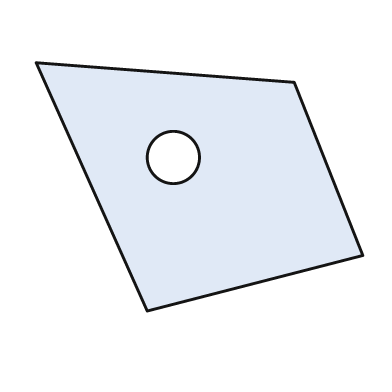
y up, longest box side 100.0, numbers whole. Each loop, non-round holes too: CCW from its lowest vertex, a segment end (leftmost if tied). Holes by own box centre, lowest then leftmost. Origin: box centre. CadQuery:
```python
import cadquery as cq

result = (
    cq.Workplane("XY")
    .moveTo(-16.0, -38.0)
    .lineTo(50.0, -21.0)
    .lineTo(29.0, 32.0)
    .lineTo(-50.0, 38.0)
    .close()
    .moveTo(-8.0, 9.0)
    .circle(8.0)
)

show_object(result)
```